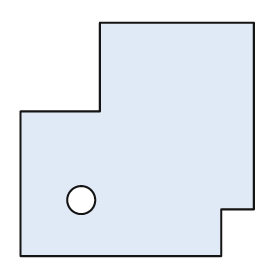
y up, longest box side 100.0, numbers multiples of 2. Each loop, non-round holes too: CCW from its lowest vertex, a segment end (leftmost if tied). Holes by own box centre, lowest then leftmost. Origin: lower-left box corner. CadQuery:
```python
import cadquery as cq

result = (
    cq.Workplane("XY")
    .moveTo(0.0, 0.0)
    .lineTo(86.0, 0.0)
    .lineTo(86.0, 20.0)
    .lineTo(100.0, 20.0)
    .lineTo(100.0, 100.0)
    .lineTo(34.0, 100.0)
    .lineTo(34.0, 62.0)
    .lineTo(0.0, 62.0)
    .close()
    .moveTo(26.0, 24.0)
    .circle(6.0)
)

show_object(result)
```